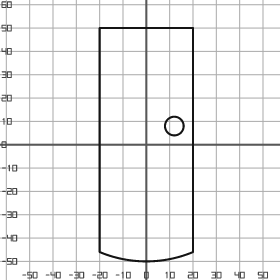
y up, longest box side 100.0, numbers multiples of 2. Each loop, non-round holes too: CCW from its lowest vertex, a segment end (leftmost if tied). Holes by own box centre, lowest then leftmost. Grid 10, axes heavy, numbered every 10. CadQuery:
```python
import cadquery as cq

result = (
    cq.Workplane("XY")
    .moveTo(-20.0, -46.0)
    .threePointArc((0.0, -50.0), (20.0, -46.0))
    .lineTo(20.0, 50.0)
    .lineTo(-20.0, 50.0)
    .close()
    .moveTo(12.0, 8.0)
    .circle(4.0)
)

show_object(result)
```